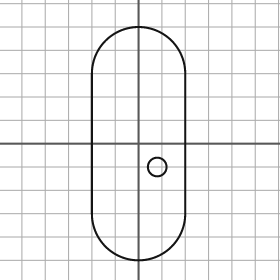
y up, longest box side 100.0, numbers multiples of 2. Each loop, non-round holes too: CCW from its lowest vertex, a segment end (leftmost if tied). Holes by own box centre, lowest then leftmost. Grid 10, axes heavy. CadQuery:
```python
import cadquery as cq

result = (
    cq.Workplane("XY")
    .moveTo(-20.0, -30.0)
    .threePointArc((0.0, -50.0), (20.0, -30.0))
    .lineTo(20.0, 30.0)
    .threePointArc((0.0, 50.0), (-20.0, 30.0))
    .close()
    .moveTo(8.0, -10.0)
    .circle(4.0)
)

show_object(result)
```